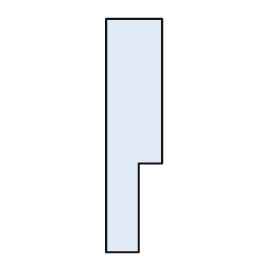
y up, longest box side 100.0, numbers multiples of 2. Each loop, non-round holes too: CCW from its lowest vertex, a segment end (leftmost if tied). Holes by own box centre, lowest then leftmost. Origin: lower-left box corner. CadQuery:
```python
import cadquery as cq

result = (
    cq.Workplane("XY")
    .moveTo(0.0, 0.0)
    .lineTo(14.0, 0.0)
    .lineTo(14.0, 38.0)
    .lineTo(24.0, 38.0)
    .lineTo(24.0, 100.0)
    .lineTo(0.0, 100.0)
    .close()
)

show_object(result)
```